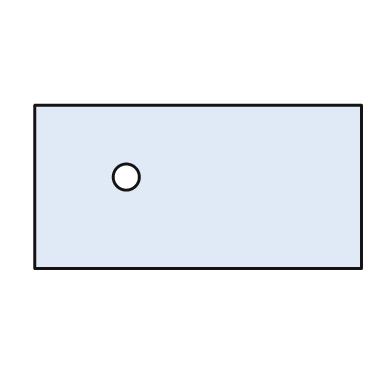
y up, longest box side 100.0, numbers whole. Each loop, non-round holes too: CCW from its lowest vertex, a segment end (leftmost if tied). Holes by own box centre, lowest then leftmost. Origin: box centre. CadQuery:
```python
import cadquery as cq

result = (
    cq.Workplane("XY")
    .moveTo(-50.0, -25.0)
    .lineTo(50.0, -25.0)
    .lineTo(50.0, 25.0)
    .lineTo(-50.0, 25.0)
    .close()
    .moveTo(-22.0, 3.0)
    .circle(4.0)
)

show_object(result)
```